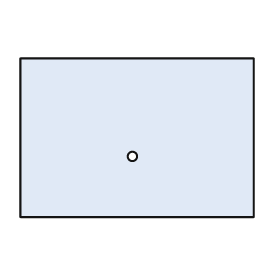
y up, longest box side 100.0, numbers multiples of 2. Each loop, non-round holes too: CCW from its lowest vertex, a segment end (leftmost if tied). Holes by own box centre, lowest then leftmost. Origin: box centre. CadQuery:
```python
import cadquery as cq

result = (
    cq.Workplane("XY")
    .moveTo(-50.0, -34.0)
    .lineTo(50.0, -34.0)
    .lineTo(50.0, 34.0)
    .lineTo(-50.0, 34.0)
    .close()
    .moveTo(-2.0, -8.0)
    .circle(2.0)
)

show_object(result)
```